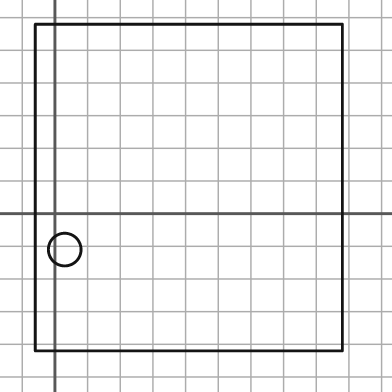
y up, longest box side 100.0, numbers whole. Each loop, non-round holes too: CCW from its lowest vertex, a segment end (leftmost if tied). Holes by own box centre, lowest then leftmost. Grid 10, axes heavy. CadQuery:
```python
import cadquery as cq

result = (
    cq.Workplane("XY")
    .moveTo(-6.0, -42.0)
    .lineTo(88.0, -42.0)
    .lineTo(88.0, 58.0)
    .lineTo(-6.0, 58.0)
    .close()
    .moveTo(3.0, -11.0)
    .circle(5.0)
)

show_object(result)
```